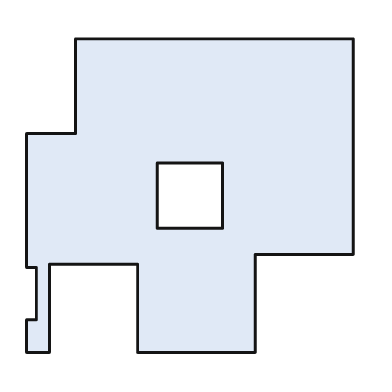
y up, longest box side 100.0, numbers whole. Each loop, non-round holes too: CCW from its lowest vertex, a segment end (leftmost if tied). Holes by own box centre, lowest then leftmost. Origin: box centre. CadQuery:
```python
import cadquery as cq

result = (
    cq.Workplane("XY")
    .moveTo(-50.0, -48.0)
    .lineTo(-43.0, -48.0)
    .lineTo(-43.0, -21.0)
    .lineTo(-16.0, -21.0)
    .lineTo(-16.0, -48.0)
    .lineTo(20.0, -48.0)
    .lineTo(20.0, -18.0)
    .lineTo(50.0, -18.0)
    .lineTo(50.0, 48.0)
    .lineTo(-35.0, 48.0)
    .lineTo(-35.0, 19.0)
    .lineTo(-50.0, 19.0)
    .lineTo(-50.0, -22.0)
    .lineTo(-47.0, -22.0)
    .lineTo(-47.0, -38.0)
    .lineTo(-50.0, -38.0)
    .close()
    .moveTo(-10.0, -10.0)
    .lineTo(10.0, -10.0)
    .lineTo(10.0, 10.0)
    .lineTo(-10.0, 10.0)
    .close()
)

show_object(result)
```